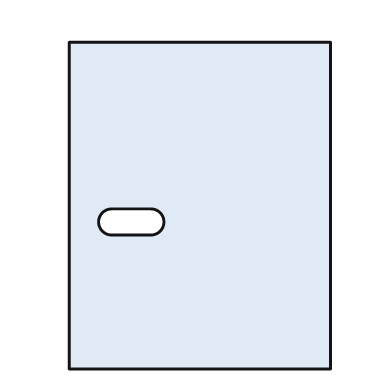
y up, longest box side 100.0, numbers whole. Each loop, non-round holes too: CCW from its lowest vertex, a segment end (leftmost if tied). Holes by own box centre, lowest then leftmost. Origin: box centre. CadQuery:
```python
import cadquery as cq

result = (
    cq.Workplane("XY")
    .moveTo(-40.0, -50.0)
    .lineTo(40.0, -50.0)
    .lineTo(40.0, 50.0)
    .lineTo(-40.0, 50.0)
    .close()
    .moveTo(-27.0, -9.0)
    .lineTo(-15.0, -9.0)
    .threePointArc((-11.0, -5.0), (-15.0, -1.0))
    .lineTo(-27.0, -1.0)
    .threePointArc((-31.0, -5.0), (-27.0, -9.0))
    .close()
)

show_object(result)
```